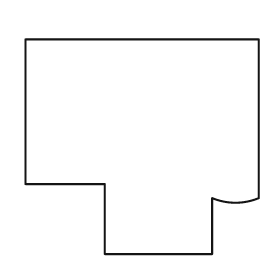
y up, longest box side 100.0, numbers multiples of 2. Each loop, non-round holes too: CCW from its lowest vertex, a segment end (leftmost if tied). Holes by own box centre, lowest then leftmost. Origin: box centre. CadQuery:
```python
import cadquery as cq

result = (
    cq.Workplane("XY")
    .moveTo(-16.0, -46.0)
    .lineTo(30.0, -46.0)
    .lineTo(30.0, -22.0)
    .threePointArc((40.0, -24.0), (50.0, -22.0))
    .lineTo(50.0, 46.0)
    .lineTo(-50.0, 46.0)
    .lineTo(-50.0, -16.0)
    .lineTo(-16.0, -16.0)
    .close()
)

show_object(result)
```